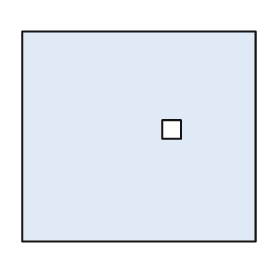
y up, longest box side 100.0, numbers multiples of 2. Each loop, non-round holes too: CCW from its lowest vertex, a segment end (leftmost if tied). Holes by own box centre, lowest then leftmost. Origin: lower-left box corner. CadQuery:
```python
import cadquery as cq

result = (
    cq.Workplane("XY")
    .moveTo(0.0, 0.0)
    .lineTo(100.0, 0.0)
    .lineTo(100.0, 90.0)
    .lineTo(0.0, 90.0)
    .close()
    .moveTo(60.0, 44.0)
    .lineTo(68.0, 44.0)
    .lineTo(68.0, 52.0)
    .lineTo(60.0, 52.0)
    .close()
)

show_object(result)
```